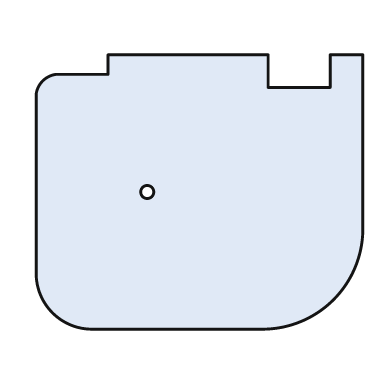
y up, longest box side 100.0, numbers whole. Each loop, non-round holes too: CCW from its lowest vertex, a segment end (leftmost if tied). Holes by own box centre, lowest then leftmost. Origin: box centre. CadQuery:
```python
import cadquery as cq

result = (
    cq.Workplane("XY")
    .moveTo(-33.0, -42.0)
    .lineTo(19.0, -42.0)
    .threePointArc((41.0, -33.0), (50.0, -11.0))
    .lineTo(50.0, 42.0)
    .lineTo(40.0, 42.0)
    .lineTo(40.0, 32.0)
    .lineTo(21.0, 32.0)
    .lineTo(21.0, 42.0)
    .lineTo(-28.0, 42.0)
    .lineTo(-28.0, 36.0)
    .lineTo(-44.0, 36.0)
    .threePointArc((-48.0, 34.0), (-50.0, 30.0))
    .lineTo(-50.0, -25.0)
    .threePointArc((-45.0, -37.0), (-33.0, -42.0))
    .close()
    .moveTo(-16.0, 0.0)
    .circle(2.0)
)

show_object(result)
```